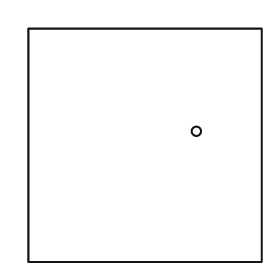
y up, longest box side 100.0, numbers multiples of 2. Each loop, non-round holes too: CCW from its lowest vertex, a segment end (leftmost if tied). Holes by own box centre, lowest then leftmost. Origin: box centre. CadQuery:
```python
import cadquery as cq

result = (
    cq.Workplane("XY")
    .moveTo(-50.0, -50.0)
    .lineTo(50.0, -50.0)
    .lineTo(50.0, 50.0)
    .lineTo(-50.0, 50.0)
    .close()
    .moveTo(22.0, 6.0)
    .circle(2.0)
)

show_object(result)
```